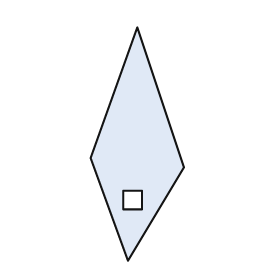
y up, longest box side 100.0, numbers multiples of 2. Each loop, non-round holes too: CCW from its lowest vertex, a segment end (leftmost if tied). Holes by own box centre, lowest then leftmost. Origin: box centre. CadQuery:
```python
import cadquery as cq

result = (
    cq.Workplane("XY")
    .moveTo(-4.0, -50.0)
    .lineTo(20.0, -10.0)
    .lineTo(0.0, 50.0)
    .lineTo(-20.0, -6.0)
    .close()
    .moveTo(-6.0, -28.0)
    .lineTo(2.0, -28.0)
    .lineTo(2.0, -20.0)
    .lineTo(-6.0, -20.0)
    .close()
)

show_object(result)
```